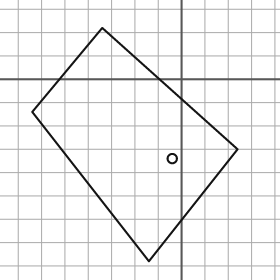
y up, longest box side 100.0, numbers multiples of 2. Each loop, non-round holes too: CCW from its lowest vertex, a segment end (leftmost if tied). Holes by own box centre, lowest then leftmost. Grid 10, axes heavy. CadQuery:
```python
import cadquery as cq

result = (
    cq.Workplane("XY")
    .moveTo(-14.0, -78.0)
    .lineTo(24.0, -30.0)
    .lineTo(-34.0, 22.0)
    .lineTo(-64.0, -14.0)
    .close()
    .moveTo(-4.0, -34.0)
    .circle(2.0)
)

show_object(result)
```